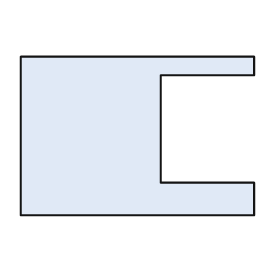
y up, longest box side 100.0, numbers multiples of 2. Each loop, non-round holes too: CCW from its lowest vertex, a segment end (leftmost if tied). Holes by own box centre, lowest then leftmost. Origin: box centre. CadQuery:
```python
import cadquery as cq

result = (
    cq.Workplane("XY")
    .moveTo(-50.0, -34.0)
    .lineTo(50.0, -34.0)
    .lineTo(50.0, -20.0)
    .lineTo(10.0, -20.0)
    .lineTo(10.0, 26.0)
    .lineTo(50.0, 26.0)
    .lineTo(50.0, 34.0)
    .lineTo(-50.0, 34.0)
    .close()
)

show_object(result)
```